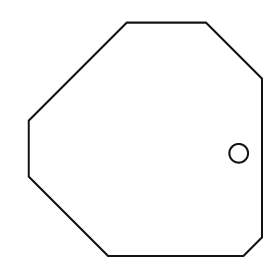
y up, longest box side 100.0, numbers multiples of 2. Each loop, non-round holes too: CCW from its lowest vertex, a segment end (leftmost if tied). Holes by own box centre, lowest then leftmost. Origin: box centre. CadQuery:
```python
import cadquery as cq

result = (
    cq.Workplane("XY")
    .moveTo(-16.0, -50.0)
    .lineTo(42.0, -50.0)
    .lineTo(50.0, -42.0)
    .lineTo(50.0, 26.0)
    .lineTo(26.0, 50.0)
    .lineTo(-8.0, 50.0)
    .lineTo(-50.0, 8.0)
    .lineTo(-50.0, -16.0)
    .close()
    .moveTo(40.0, -6.0)
    .circle(4.0)
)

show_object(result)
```